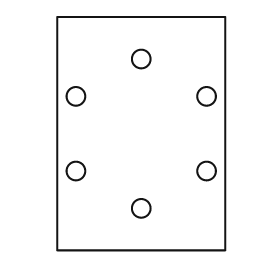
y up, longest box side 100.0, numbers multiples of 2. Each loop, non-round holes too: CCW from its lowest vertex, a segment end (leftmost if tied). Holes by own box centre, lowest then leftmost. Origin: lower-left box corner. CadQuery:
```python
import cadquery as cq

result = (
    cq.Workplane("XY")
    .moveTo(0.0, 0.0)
    .lineTo(72.0, 0.0)
    .lineTo(72.0, 100.0)
    .lineTo(0.0, 100.0)
    .close()
    .moveTo(36.0, 18.0)
    .circle(4.0)
    .moveTo(8.0, 34.0)
    .circle(4.0)
    .moveTo(64.0, 34.0)
    .circle(4.0)
    .moveTo(8.0, 66.0)
    .circle(4.0)
    .moveTo(64.0, 66.0)
    .circle(4.0)
    .moveTo(36.0, 82.0)
    .circle(4.0)
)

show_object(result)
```